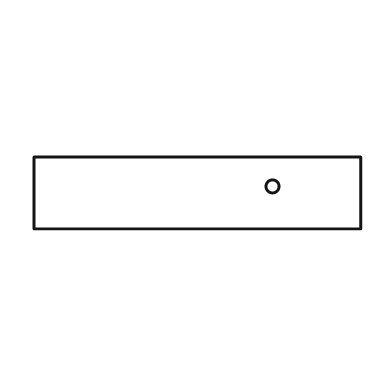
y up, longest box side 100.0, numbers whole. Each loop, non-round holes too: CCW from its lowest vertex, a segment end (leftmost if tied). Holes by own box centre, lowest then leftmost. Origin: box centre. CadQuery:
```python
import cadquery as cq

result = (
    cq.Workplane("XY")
    .moveTo(-50.0, -11.0)
    .lineTo(50.0, -11.0)
    .lineTo(50.0, 11.0)
    .lineTo(-50.0, 11.0)
    .close()
    .moveTo(23.0, 2.0)
    .circle(2.0)
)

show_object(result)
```